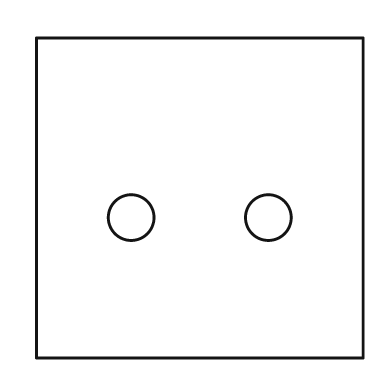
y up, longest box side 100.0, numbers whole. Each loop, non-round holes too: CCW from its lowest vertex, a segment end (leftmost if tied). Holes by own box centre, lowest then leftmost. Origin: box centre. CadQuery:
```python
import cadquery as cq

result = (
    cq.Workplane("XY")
    .moveTo(-50.0, -49.0)
    .lineTo(50.0, -49.0)
    .lineTo(50.0, 49.0)
    .lineTo(-50.0, 49.0)
    .close()
    .moveTo(-21.0, -6.0)
    .circle(7.0)
    .moveTo(21.0, -6.0)
    .circle(7.0)
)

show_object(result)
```